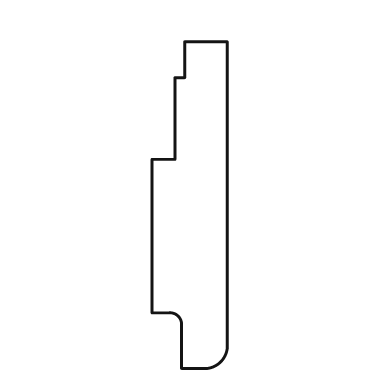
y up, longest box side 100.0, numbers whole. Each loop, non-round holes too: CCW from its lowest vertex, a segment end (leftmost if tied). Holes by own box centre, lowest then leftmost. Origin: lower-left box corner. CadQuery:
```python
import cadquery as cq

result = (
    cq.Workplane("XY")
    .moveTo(9.0, 0.0)
    .lineTo(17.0, 0.0)
    .threePointArc((21.0, 2.0), (23.0, 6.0))
    .lineTo(23.0, 100.0)
    .lineTo(10.0, 100.0)
    .lineTo(10.0, 89.0)
    .lineTo(7.0, 89.0)
    .lineTo(7.0, 64.0)
    .lineTo(0.0, 64.0)
    .lineTo(0.0, 17.0)
    .lineTo(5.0, 17.0)
    .threePointArc((8.0, 16.0), (9.0, 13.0))
    .close()
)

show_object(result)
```